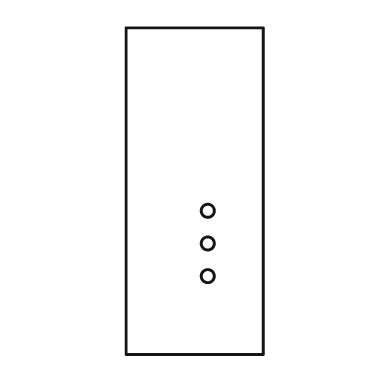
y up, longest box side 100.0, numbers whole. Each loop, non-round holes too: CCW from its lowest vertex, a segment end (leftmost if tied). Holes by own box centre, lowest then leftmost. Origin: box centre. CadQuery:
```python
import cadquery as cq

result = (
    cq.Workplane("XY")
    .moveTo(-21.0, -50.0)
    .lineTo(21.0, -50.0)
    .lineTo(21.0, 50.0)
    .lineTo(-21.0, 50.0)
    .close()
    .moveTo(4.0, -26.0)
    .circle(2.0)
    .moveTo(4.0, -16.0)
    .circle(2.0)
    .moveTo(4.0, -6.0)
    .circle(2.0)
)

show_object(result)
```